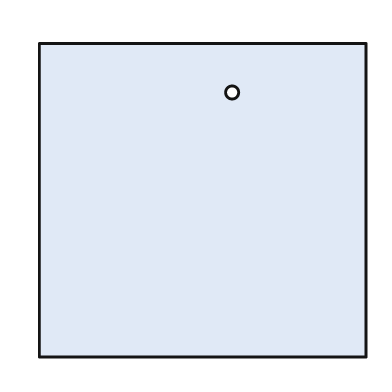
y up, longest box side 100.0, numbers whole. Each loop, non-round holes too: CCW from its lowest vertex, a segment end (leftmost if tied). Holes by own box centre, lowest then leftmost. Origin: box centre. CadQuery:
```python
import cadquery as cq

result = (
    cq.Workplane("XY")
    .moveTo(-50.0, -48.0)
    .lineTo(50.0, -48.0)
    .lineTo(50.0, 48.0)
    .lineTo(-50.0, 48.0)
    .close()
    .moveTo(9.0, 33.0)
    .circle(2.0)
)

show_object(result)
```